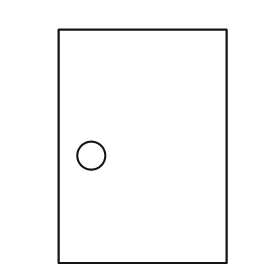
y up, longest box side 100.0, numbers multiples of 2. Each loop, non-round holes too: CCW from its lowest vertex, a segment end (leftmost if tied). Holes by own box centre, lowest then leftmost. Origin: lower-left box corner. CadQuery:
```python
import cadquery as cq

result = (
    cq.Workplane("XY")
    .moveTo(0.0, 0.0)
    .lineTo(72.0, 0.0)
    .lineTo(72.0, 100.0)
    .lineTo(0.0, 100.0)
    .close()
    .moveTo(14.0, 46.0)
    .circle(6.0)
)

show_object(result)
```